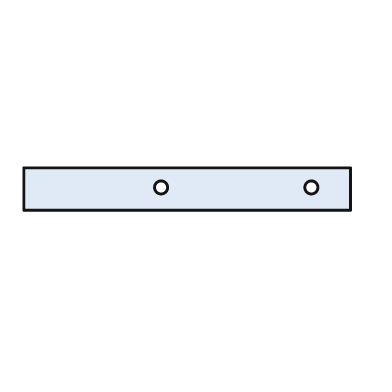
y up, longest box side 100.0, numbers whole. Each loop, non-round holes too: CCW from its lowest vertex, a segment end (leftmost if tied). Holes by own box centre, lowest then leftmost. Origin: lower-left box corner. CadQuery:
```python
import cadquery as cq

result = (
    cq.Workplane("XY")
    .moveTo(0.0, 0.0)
    .lineTo(100.0, 0.0)
    .lineTo(100.0, 13.0)
    .lineTo(0.0, 13.0)
    .close()
    .moveTo(42.0, 7.0)
    .circle(2.0)
    .moveTo(88.0, 7.0)
    .circle(2.0)
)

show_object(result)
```